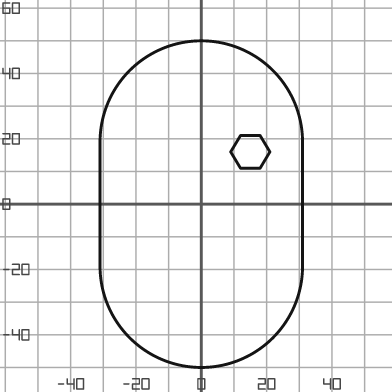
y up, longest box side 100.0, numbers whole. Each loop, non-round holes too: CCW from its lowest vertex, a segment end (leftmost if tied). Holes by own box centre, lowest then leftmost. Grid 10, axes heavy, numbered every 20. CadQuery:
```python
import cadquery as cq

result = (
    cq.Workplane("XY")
    .moveTo(-31.0, -19.0)
    .threePointArc((0.0, -50.0), (31.0, -19.0))
    .lineTo(31.0, 19.0)
    .threePointArc((0.0, 50.0), (-31.0, 19.0))
    .close()
    .moveTo(12.0, 11.0)
    .lineTo(18.0, 11.0)
    .lineTo(21.0, 16.0)
    .lineTo(18.0, 21.0)
    .lineTo(12.0, 21.0)
    .lineTo(9.0, 16.0)
    .close()
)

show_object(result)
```